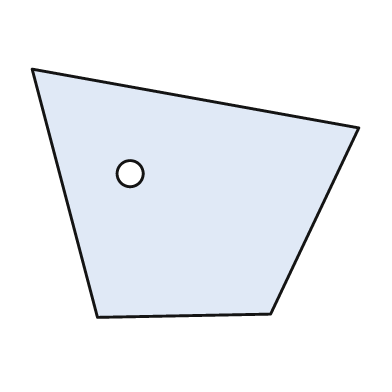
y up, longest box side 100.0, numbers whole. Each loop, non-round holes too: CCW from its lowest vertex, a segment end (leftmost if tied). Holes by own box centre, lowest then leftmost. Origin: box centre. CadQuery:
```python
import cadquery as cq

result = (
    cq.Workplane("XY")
    .moveTo(-30.0, -38.0)
    .lineTo(23.0, -37.0)
    .lineTo(50.0, 20.0)
    .lineTo(-50.0, 38.0)
    .close()
    .moveTo(-20.0, 6.0)
    .circle(4.0)
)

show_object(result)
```